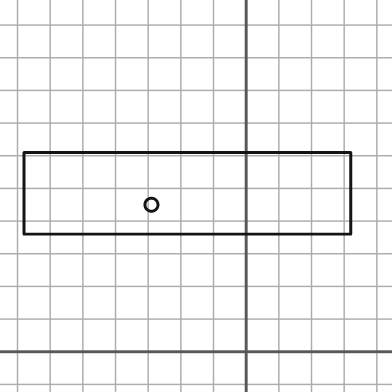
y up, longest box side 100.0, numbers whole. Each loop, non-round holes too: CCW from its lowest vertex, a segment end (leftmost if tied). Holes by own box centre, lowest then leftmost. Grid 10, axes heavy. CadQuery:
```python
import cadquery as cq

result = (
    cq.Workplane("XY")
    .moveTo(-68.0, 36.0)
    .lineTo(32.0, 36.0)
    .lineTo(32.0, 61.0)
    .lineTo(-68.0, 61.0)
    .close()
    .moveTo(-29.0, 45.0)
    .circle(2.0)
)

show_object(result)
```